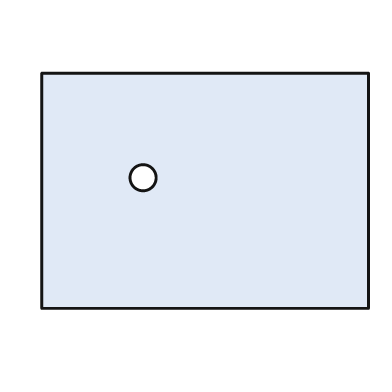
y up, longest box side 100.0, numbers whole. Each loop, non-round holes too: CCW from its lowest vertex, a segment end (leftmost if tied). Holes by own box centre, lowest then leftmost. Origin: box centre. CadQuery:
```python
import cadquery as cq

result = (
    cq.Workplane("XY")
    .moveTo(-50.0, -36.0)
    .lineTo(50.0, -36.0)
    .lineTo(50.0, 36.0)
    .lineTo(-50.0, 36.0)
    .close()
    .moveTo(-19.0, 4.0)
    .circle(4.0)
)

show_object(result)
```